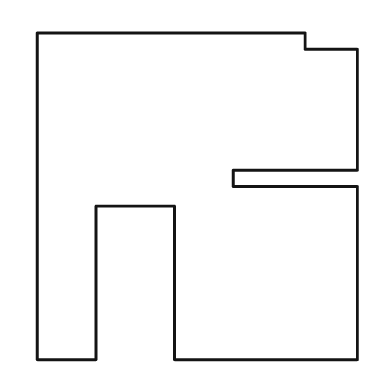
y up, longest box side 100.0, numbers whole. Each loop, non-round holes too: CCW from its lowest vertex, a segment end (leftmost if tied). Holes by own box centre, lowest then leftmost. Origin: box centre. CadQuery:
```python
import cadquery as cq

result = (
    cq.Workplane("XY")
    .moveTo(-49.0, -50.0)
    .lineTo(-31.0, -50.0)
    .lineTo(-31.0, -3.0)
    .lineTo(-7.0, -3.0)
    .lineTo(-7.0, -50.0)
    .lineTo(49.0, -50.0)
    .lineTo(49.0, 3.0)
    .lineTo(11.0, 3.0)
    .lineTo(11.0, 8.0)
    .lineTo(49.0, 8.0)
    .lineTo(49.0, 45.0)
    .lineTo(33.0, 45.0)
    .lineTo(33.0, 50.0)
    .lineTo(-49.0, 50.0)
    .close()
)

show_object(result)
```